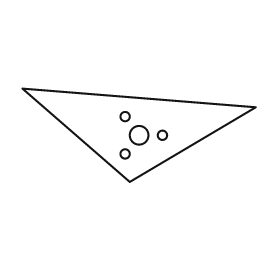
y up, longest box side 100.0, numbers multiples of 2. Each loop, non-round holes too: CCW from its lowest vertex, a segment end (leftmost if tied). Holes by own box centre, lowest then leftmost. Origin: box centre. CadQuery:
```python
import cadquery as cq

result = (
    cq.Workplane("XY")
    .moveTo(-4.0, -20.0)
    .lineTo(50.0, 12.0)
    .lineTo(-50.0, 20.0)
    .close()
    .moveTo(-6.0, -8.0)
    .circle(2.0)
    .moveTo(0.0, 0.0)
    .circle(4.0)
    .moveTo(10.0, 0.0)
    .circle(2.0)
    .moveTo(-6.0, 8.0)
    .circle(2.0)
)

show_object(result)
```